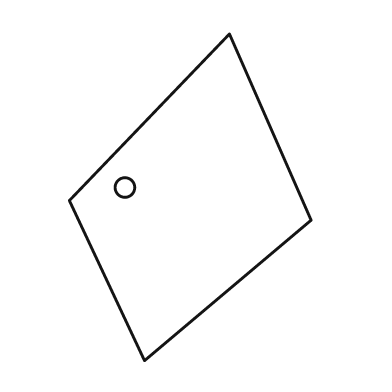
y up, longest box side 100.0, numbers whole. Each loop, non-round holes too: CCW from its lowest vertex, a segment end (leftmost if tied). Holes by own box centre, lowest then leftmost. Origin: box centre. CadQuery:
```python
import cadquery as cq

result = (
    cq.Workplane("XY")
    .moveTo(-14.0, -50.0)
    .lineTo(37.0, -7.0)
    .lineTo(12.0, 50.0)
    .lineTo(-37.0, -1.0)
    .close()
    .moveTo(-20.0, 3.0)
    .circle(3.0)
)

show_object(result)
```